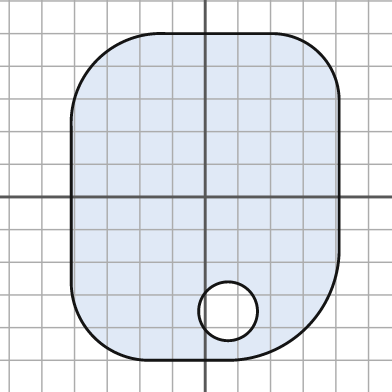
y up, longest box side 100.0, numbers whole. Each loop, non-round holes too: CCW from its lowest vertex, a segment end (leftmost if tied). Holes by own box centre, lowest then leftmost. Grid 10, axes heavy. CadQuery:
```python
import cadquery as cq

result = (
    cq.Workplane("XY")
    .moveTo(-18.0, -50.0)
    .lineTo(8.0, -50.0)
    .threePointArc((31.0, -40.0), (41.0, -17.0))
    .lineTo(41.0, 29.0)
    .threePointArc((35.0, 44.0), (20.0, 50.0))
    .lineTo(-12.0, 50.0)
    .threePointArc((-33.0, 42.0), (-41.0, 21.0))
    .lineTo(-41.0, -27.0)
    .threePointArc((-34.0, -43.0), (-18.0, -50.0))
    .close()
    .moveTo(7.0, -35.0)
    .circle(9.0)
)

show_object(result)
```